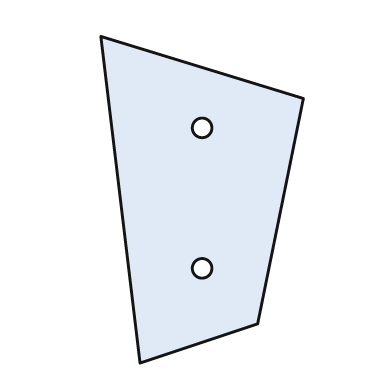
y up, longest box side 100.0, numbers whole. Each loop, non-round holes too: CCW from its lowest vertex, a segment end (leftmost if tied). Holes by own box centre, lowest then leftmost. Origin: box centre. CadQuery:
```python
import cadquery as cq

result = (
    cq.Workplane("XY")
    .moveTo(-19.0, -50.0)
    .lineTo(17.0, -38.0)
    .lineTo(31.0, 31.0)
    .lineTo(-31.0, 50.0)
    .close()
    .moveTo(0.0, -21.0)
    .circle(3.0)
    .moveTo(0.0, 22.0)
    .circle(3.0)
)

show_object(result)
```